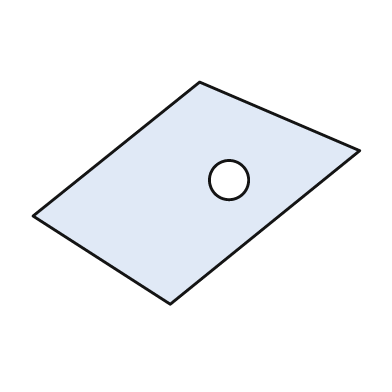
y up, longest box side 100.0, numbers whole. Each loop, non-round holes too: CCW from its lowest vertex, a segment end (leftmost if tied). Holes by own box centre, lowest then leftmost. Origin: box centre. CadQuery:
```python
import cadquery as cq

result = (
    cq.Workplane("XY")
    .moveTo(-8.0, -34.0)
    .lineTo(50.0, 13.0)
    .lineTo(1.0, 34.0)
    .lineTo(-50.0, -7.0)
    .close()
    .moveTo(10.0, 4.0)
    .circle(6.0)
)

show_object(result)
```